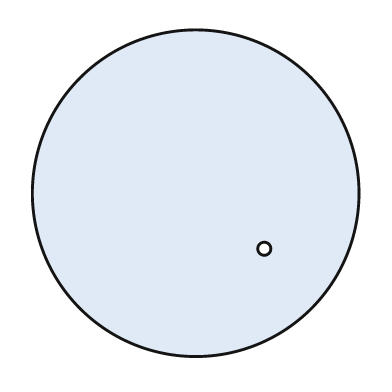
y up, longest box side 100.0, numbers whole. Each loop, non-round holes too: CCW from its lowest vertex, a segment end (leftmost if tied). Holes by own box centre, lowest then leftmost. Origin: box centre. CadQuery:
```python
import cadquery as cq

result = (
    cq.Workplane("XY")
    .moveTo(0.0, 0.0)
    .circle(50.0)
    .moveTo(21.0, -17.0)
    .circle(2.0)
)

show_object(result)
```